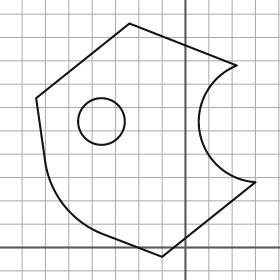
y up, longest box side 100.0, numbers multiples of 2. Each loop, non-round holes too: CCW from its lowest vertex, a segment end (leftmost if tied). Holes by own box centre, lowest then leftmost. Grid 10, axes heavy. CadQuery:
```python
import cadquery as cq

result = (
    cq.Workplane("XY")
    .moveTo(-10.0, -4.0)
    .lineTo(30.0, 28.0)
    .threePointArc((6.0, 50.0), (22.0, 78.0))
    .lineTo(-24.0, 96.0)
    .lineTo(-64.0, 64.0)
    .lineTo(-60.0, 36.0)
    .threePointArc((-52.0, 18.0), (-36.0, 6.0))
    .close()
    .moveTo(-36.0, 54.0)
    .circle(10.0)
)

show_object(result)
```